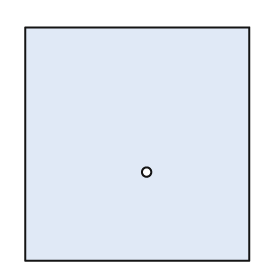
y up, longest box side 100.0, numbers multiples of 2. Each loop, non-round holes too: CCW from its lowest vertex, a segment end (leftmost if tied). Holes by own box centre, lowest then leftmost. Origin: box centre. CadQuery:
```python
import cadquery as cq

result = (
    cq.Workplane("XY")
    .moveTo(-48.0, -50.0)
    .lineTo(48.0, -50.0)
    .lineTo(48.0, 50.0)
    .lineTo(-48.0, 50.0)
    .close()
    .moveTo(4.0, -12.0)
    .circle(2.0)
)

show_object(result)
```